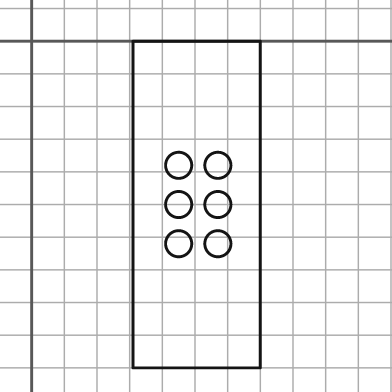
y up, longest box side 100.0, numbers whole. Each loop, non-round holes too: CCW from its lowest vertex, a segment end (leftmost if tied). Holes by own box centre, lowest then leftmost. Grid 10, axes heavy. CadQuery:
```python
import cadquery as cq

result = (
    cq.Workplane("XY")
    .moveTo(31.0, -100.0)
    .lineTo(70.0, -100.0)
    .lineTo(70.0, 0.0)
    .lineTo(31.0, 0.0)
    .close()
    .moveTo(45.0, -62.0)
    .circle(4.0)
    .moveTo(57.0, -62.0)
    .circle(4.0)
    .moveTo(45.0, -50.0)
    .circle(4.0)
    .moveTo(57.0, -50.0)
    .circle(4.0)
    .moveTo(45.0, -38.0)
    .circle(4.0)
    .moveTo(57.0, -38.0)
    .circle(4.0)
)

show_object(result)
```